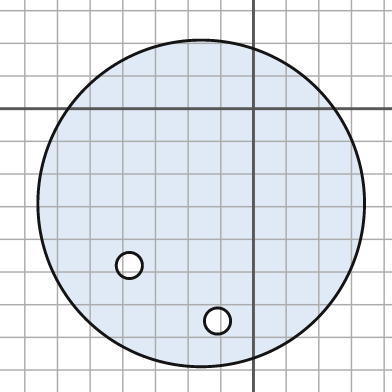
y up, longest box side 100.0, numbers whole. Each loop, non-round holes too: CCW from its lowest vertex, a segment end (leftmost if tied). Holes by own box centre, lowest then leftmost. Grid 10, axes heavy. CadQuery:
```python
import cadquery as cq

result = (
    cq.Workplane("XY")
    .moveTo(-16.0, -29.0)
    .circle(50.0)
    .moveTo(-11.0, -65.0)
    .circle(4.0)
    .moveTo(-38.0, -48.0)
    .circle(4.0)
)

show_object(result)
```